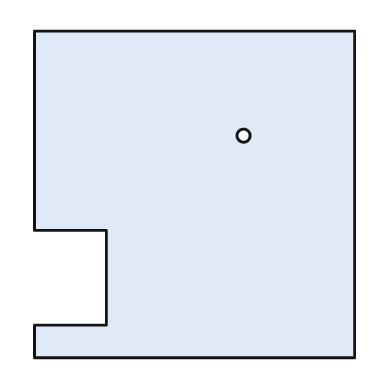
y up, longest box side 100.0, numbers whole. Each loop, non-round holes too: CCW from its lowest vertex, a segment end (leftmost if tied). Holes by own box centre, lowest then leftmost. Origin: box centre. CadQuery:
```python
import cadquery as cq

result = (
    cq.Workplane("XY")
    .moveTo(-49.0, -50.0)
    .lineTo(49.0, -50.0)
    .lineTo(49.0, 50.0)
    .lineTo(-49.0, 50.0)
    .lineTo(-49.0, -11.0)
    .lineTo(-27.0, -11.0)
    .lineTo(-27.0, -40.0)
    .lineTo(-49.0, -40.0)
    .close()
    .moveTo(15.0, 18.0)
    .circle(2.0)
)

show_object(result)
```